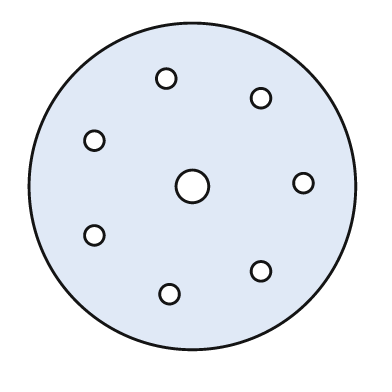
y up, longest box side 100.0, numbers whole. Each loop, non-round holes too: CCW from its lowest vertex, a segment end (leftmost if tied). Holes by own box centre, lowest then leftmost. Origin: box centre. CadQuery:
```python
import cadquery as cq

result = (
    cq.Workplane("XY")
    .moveTo(0.0, 0.0)
    .circle(50.0)
    .moveTo(-7.0, -33.0)
    .circle(3.0)
    .moveTo(21.0, -26.0)
    .circle(3.0)
    .moveTo(-30.0, -15.0)
    .circle(3.0)
    .moveTo(0.0, 0.0)
    .circle(5.0)
    .moveTo(34.0, 1.0)
    .circle(3.0)
    .moveTo(-30.0, 14.0)
    .circle(3.0)
    .moveTo(21.0, 27.0)
    .circle(3.0)
    .moveTo(-8.0, 33.0)
    .circle(3.0)
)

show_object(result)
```